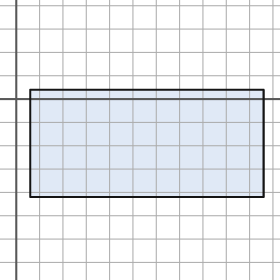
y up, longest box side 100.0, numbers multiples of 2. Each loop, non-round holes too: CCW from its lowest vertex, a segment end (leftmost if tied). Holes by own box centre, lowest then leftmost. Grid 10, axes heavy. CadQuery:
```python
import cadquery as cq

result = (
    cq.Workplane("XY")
    .moveTo(6.0, -42.0)
    .lineTo(106.0, -42.0)
    .lineTo(106.0, 4.0)
    .lineTo(6.0, 4.0)
    .close()
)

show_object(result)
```